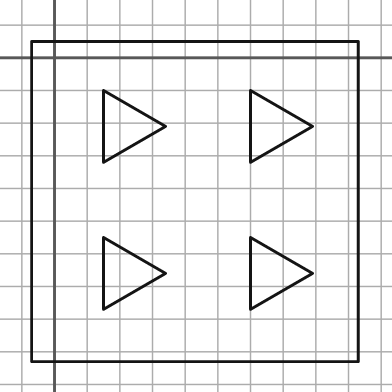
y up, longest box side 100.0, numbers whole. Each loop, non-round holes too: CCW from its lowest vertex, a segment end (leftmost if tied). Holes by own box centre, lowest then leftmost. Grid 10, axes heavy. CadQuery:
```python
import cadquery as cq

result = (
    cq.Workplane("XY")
    .moveTo(-7.0, -93.0)
    .lineTo(93.0, -93.0)
    .lineTo(93.0, 5.0)
    .lineTo(-7.0, 5.0)
    .close()
    .moveTo(15.0, -77.0)
    .lineTo(34.0, -66.0)
    .lineTo(15.0, -55.0)
    .close()
    .moveTo(60.0, -77.0)
    .lineTo(79.0, -66.0)
    .lineTo(60.0, -55.0)
    .close()
    .moveTo(15.0, -32.0)
    .lineTo(34.0, -21.0)
    .lineTo(15.0, -10.0)
    .close()
    .moveTo(60.0, -32.0)
    .lineTo(79.0, -21.0)
    .lineTo(60.0, -10.0)
    .close()
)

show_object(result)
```